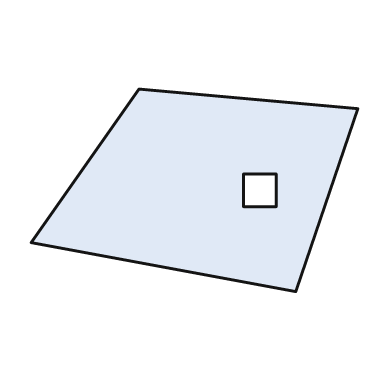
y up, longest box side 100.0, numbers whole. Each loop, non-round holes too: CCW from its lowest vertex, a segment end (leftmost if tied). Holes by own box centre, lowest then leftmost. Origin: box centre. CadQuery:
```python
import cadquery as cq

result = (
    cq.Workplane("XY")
    .moveTo(31.0, -31.0)
    .lineTo(50.0, 25.0)
    .lineTo(-17.0, 31.0)
    .lineTo(-50.0, -16.0)
    .close()
    .moveTo(15.0, -5.0)
    .lineTo(25.0, -5.0)
    .lineTo(25.0, 5.0)
    .lineTo(15.0, 5.0)
    .close()
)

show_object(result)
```